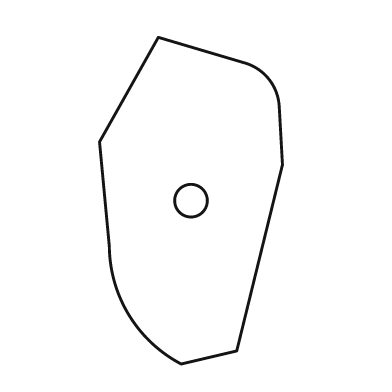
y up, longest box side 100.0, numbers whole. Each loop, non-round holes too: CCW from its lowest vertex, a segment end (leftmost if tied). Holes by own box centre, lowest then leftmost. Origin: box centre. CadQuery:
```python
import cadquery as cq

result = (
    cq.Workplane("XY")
    .moveTo(-3.0, -50.0)
    .lineTo(14.0, -46.0)
    .lineTo(28.0, 11.0)
    .lineTo(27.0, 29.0)
    .threePointArc((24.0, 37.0), (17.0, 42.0))
    .lineTo(-10.0, 50.0)
    .lineTo(-28.0, 18.0)
    .lineTo(-25.0, -14.0)
    .threePointArc((-19.0, -35.0), (-3.0, -50.0))
    .close()
    .moveTo(0.0, 0.0)
    .circle(5.0)
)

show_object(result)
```